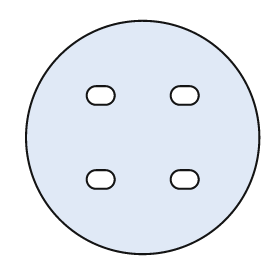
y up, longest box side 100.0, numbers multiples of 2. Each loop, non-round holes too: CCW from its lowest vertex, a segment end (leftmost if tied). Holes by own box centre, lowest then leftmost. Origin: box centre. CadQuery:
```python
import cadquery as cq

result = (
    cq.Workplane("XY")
    .moveTo(0.0, 0.0)
    .circle(50.0)
    .moveTo(-20.0, -22.0)
    .lineTo(-16.0, -22.0)
    .threePointArc((-12.0, -18.0), (-16.0, -14.0))
    .lineTo(-20.0, -14.0)
    .threePointArc((-24.0, -18.0), (-20.0, -22.0))
    .close()
    .moveTo(16.0, -22.0)
    .lineTo(20.0, -22.0)
    .threePointArc((24.0, -18.0), (20.0, -14.0))
    .lineTo(16.0, -14.0)
    .threePointArc((12.0, -18.0), (16.0, -22.0))
    .close()
    .moveTo(-20.0, 14.0)
    .lineTo(-16.0, 14.0)
    .threePointArc((-12.0, 18.0), (-16.0, 22.0))
    .lineTo(-20.0, 22.0)
    .threePointArc((-24.0, 18.0), (-20.0, 14.0))
    .close()
    .moveTo(16.0, 14.0)
    .lineTo(20.0, 14.0)
    .threePointArc((24.0, 18.0), (20.0, 22.0))
    .lineTo(16.0, 22.0)
    .threePointArc((12.0, 18.0), (16.0, 14.0))
    .close()
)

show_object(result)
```